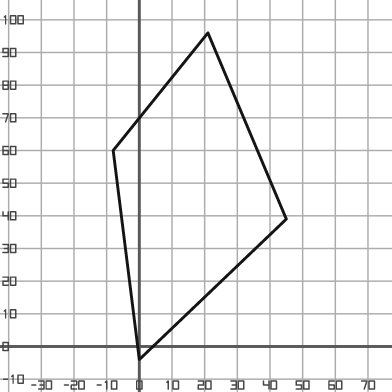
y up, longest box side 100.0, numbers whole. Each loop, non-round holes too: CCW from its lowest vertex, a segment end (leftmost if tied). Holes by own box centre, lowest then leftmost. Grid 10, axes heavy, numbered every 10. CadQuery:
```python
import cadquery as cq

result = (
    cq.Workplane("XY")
    .moveTo(0.0, -4.0)
    .lineTo(45.0, 39.0)
    .lineTo(21.0, 96.0)
    .lineTo(-8.0, 60.0)
    .close()
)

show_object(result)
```